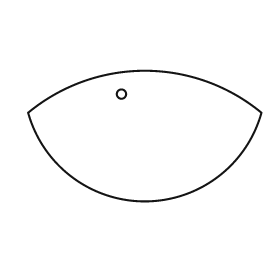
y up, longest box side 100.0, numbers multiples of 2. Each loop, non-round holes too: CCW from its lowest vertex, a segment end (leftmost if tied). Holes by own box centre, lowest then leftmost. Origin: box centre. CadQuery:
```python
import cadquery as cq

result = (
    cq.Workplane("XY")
    .moveTo(-50.0, 10.0)
    .threePointArc((0.0, -28.0), (50.0, 10.0))
    .threePointArc((0.0, 28.0), (-50.0, 10.0))
    .close()
    .moveTo(-10.0, 18.0)
    .circle(2.0)
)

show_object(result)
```